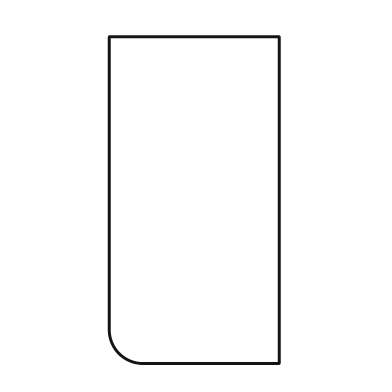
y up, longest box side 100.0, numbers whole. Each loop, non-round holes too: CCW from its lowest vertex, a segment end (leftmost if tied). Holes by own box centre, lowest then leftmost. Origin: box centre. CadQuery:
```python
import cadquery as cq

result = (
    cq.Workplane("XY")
    .moveTo(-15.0, -50.0)
    .lineTo(26.0, -50.0)
    .lineTo(26.0, 50.0)
    .lineTo(-26.0, 50.0)
    .lineTo(-26.0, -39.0)
    .threePointArc((-23.0, -47.0), (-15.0, -50.0))
    .close()
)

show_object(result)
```